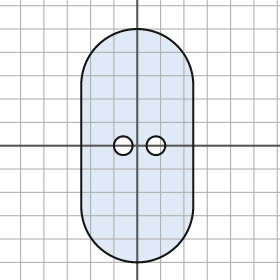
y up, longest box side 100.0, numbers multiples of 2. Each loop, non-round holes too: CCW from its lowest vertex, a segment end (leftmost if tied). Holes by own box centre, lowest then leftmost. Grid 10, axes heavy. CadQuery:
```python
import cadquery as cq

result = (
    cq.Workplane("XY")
    .moveTo(-24.0, -26.0)
    .threePointArc((0.0, -50.0), (24.0, -26.0))
    .lineTo(24.0, 26.0)
    .threePointArc((0.0, 50.0), (-24.0, 26.0))
    .close()
    .moveTo(-6.0, 0.0)
    .circle(4.0)
    .moveTo(8.0, 0.0)
    .circle(4.0)
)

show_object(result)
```